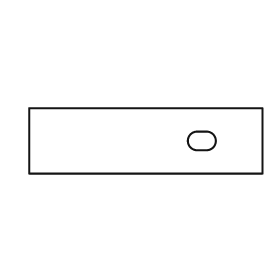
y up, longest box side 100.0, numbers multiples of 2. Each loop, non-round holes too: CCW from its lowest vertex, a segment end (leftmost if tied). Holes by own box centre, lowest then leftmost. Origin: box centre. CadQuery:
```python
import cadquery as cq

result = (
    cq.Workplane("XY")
    .moveTo(-50.0, -14.0)
    .lineTo(50.0, -14.0)
    .lineTo(50.0, 14.0)
    .lineTo(-50.0, 14.0)
    .close()
    .moveTo(22.0, -4.0)
    .lineTo(26.0, -4.0)
    .threePointArc((30.0, 0.0), (26.0, 4.0))
    .lineTo(22.0, 4.0)
    .threePointArc((18.0, 0.0), (22.0, -4.0))
    .close()
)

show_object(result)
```